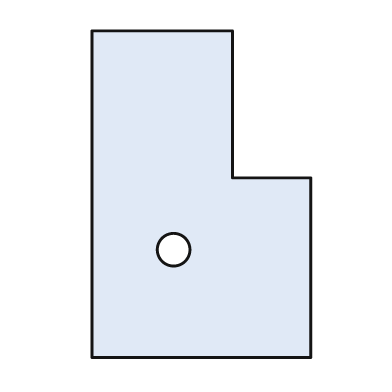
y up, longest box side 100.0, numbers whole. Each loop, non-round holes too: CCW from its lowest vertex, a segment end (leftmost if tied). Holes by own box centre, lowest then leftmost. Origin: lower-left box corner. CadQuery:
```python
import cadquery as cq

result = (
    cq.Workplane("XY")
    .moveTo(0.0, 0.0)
    .lineTo(67.0, 0.0)
    .lineTo(67.0, 55.0)
    .lineTo(43.0, 55.0)
    .lineTo(43.0, 100.0)
    .lineTo(0.0, 100.0)
    .close()
    .moveTo(25.0, 33.0)
    .circle(5.0)
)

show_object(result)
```